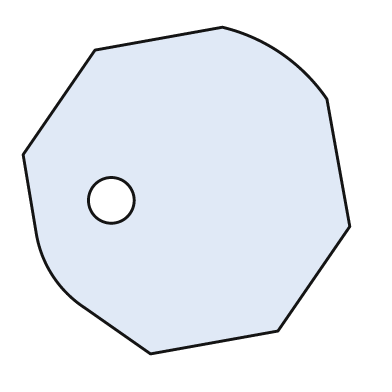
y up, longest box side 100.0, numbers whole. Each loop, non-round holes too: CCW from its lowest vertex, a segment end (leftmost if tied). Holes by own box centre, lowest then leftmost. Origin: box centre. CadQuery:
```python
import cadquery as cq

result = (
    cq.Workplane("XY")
    .moveTo(-11.0, -50.0)
    .lineTo(28.0, -43.0)
    .lineTo(50.0, -11.0)
    .lineTo(43.0, 28.0)
    .threePointArc((29.0, 42.0), (11.0, 50.0))
    .lineTo(-28.0, 43.0)
    .lineTo(-50.0, 11.0)
    .lineTo(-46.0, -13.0)
    .threePointArc((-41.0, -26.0), (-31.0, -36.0))
    .close()
    .moveTo(-23.0, -3.0)
    .circle(7.0)
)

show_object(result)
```